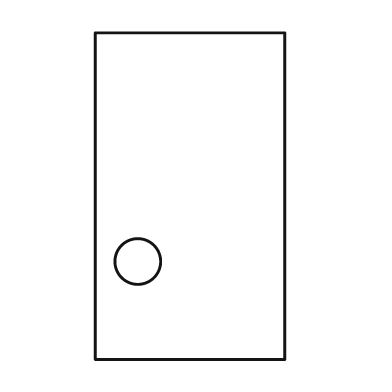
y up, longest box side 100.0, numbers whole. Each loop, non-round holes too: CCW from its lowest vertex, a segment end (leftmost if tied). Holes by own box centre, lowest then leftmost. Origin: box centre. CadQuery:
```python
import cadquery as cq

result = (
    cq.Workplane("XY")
    .moveTo(-29.0, -50.0)
    .lineTo(29.0, -50.0)
    .lineTo(29.0, 50.0)
    .lineTo(-29.0, 50.0)
    .close()
    .moveTo(-16.0, -20.0)
    .circle(7.0)
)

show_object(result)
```